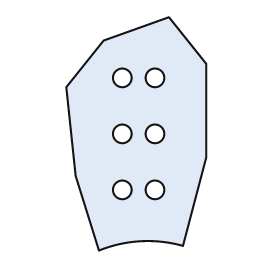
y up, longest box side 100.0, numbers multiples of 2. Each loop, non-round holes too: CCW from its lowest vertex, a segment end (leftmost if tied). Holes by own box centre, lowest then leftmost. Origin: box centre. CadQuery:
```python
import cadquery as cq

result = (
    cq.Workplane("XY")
    .moveTo(-16.0, -50.0)
    .threePointArc((2.0, -46.0), (20.0, -48.0))
    .lineTo(30.0, -10.0)
    .lineTo(30.0, 30.0)
    .lineTo(14.0, 50.0)
    .lineTo(-14.0, 40.0)
    .lineTo(-30.0, 20.0)
    .lineTo(-26.0, -18.0)
    .close()
    .moveTo(-6.0, -24.0)
    .circle(4.0)
    .moveTo(8.0, -24.0)
    .circle(4.0)
    .moveTo(-6.0, 0.0)
    .circle(4.0)
    .moveTo(8.0, 0.0)
    .circle(4.0)
    .moveTo(-6.0, 24.0)
    .circle(4.0)
    .moveTo(8.0, 24.0)
    .circle(4.0)
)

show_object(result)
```